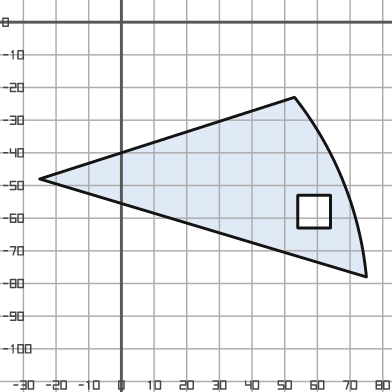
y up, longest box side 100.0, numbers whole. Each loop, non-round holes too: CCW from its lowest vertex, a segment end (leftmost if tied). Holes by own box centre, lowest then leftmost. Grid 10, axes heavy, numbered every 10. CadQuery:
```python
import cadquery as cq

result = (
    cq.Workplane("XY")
    .moveTo(75.0, -78.0)
    .threePointArc((68.0, -49.0), (53.0, -23.0))
    .lineTo(-25.0, -48.0)
    .close()
    .moveTo(54.0, -63.0)
    .lineTo(64.0, -63.0)
    .lineTo(64.0, -53.0)
    .lineTo(54.0, -53.0)
    .close()
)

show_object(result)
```